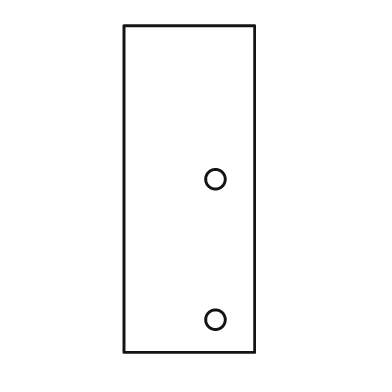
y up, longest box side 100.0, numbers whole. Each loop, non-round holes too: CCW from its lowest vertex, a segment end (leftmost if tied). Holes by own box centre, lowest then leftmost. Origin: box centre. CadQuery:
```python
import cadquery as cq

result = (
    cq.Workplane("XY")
    .moveTo(-20.0, -50.0)
    .lineTo(20.0, -50.0)
    .lineTo(20.0, 50.0)
    .lineTo(-20.0, 50.0)
    .close()
    .moveTo(8.0, -40.0)
    .circle(3.0)
    .moveTo(8.0, 3.0)
    .circle(3.0)
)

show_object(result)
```